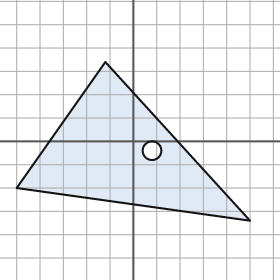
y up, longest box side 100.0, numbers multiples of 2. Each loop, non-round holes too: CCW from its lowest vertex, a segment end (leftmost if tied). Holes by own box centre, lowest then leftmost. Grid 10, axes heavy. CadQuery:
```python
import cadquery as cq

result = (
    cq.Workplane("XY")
    .moveTo(50.0, -34.0)
    .lineTo(-12.0, 34.0)
    .lineTo(-50.0, -20.0)
    .close()
    .moveTo(8.0, -4.0)
    .circle(4.0)
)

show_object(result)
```